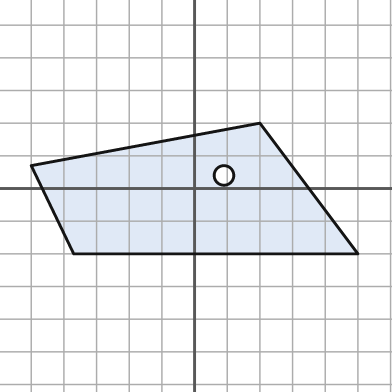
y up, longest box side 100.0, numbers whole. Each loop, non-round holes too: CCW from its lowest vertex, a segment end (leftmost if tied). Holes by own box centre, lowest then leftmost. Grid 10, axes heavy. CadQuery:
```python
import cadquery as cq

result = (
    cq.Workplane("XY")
    .moveTo(-37.0, -20.0)
    .lineTo(50.0, -20.0)
    .lineTo(20.0, 20.0)
    .lineTo(-50.0, 7.0)
    .close()
    .moveTo(9.0, 4.0)
    .circle(3.0)
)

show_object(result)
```